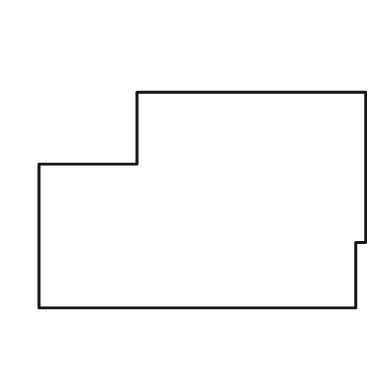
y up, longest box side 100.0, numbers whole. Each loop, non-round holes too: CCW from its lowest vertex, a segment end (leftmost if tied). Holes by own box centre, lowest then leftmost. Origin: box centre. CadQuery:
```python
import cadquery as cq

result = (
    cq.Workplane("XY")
    .moveTo(-50.0, -33.0)
    .lineTo(47.0, -33.0)
    .lineTo(47.0, -13.0)
    .lineTo(50.0, -13.0)
    .lineTo(50.0, 33.0)
    .lineTo(-20.0, 33.0)
    .lineTo(-20.0, 11.0)
    .lineTo(-50.0, 11.0)
    .close()
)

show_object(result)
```